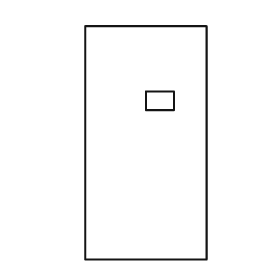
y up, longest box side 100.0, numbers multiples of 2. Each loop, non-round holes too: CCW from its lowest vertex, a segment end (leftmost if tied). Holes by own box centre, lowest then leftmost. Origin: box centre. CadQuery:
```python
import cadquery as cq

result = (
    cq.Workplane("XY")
    .moveTo(-26.0, -50.0)
    .lineTo(26.0, -50.0)
    .lineTo(26.0, 50.0)
    .lineTo(-26.0, 50.0)
    .close()
    .moveTo(0.0, 14.0)
    .lineTo(12.0, 14.0)
    .lineTo(12.0, 22.0)
    .lineTo(0.0, 22.0)
    .close()
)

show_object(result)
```